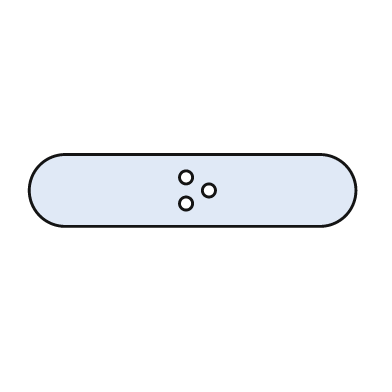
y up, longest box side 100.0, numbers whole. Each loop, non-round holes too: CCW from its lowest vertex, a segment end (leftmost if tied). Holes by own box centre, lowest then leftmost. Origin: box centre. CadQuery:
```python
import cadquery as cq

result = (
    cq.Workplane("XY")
    .moveTo(-39.0, -11.0)
    .lineTo(39.0, -11.0)
    .threePointArc((50.0, 0.0), (39.0, 11.0))
    .lineTo(-39.0, 11.0)
    .threePointArc((-50.0, 0.0), (-39.0, -11.0))
    .close()
    .moveTo(-2.0, -4.0)
    .circle(2.0)
    .moveTo(5.0, 0.0)
    .circle(2.0)
    .moveTo(-2.0, 4.0)
    .circle(2.0)
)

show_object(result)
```